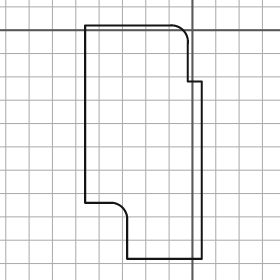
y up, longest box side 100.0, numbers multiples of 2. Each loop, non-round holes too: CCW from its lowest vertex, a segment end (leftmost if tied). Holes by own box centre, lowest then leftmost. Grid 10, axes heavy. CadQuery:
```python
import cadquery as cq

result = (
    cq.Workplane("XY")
    .moveTo(-28.0, -98.0)
    .lineTo(4.0, -98.0)
    .lineTo(4.0, -22.0)
    .lineTo(-2.0, -22.0)
    .lineTo(-2.0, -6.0)
    .threePointArc((-4.0, 0.0), (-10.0, 2.0))
    .lineTo(-46.0, 2.0)
    .lineTo(-46.0, -74.0)
    .lineTo(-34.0, -74.0)
    .threePointArc((-30.0, -76.0), (-28.0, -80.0))
    .close()
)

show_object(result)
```